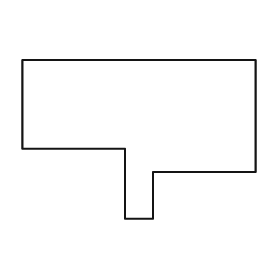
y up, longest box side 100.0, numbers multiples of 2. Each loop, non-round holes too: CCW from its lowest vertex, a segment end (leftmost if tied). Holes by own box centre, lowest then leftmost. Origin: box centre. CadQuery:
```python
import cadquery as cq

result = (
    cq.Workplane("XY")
    .moveTo(-6.0, -34.0)
    .lineTo(6.0, -34.0)
    .lineTo(6.0, -14.0)
    .lineTo(50.0, -14.0)
    .lineTo(50.0, 34.0)
    .lineTo(-50.0, 34.0)
    .lineTo(-50.0, -4.0)
    .lineTo(-6.0, -4.0)
    .close()
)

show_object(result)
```